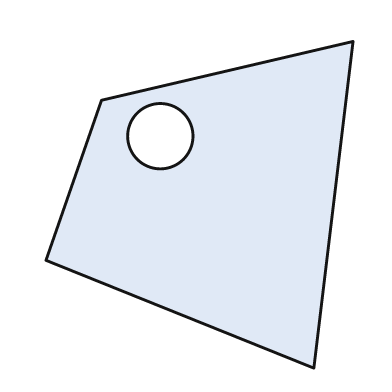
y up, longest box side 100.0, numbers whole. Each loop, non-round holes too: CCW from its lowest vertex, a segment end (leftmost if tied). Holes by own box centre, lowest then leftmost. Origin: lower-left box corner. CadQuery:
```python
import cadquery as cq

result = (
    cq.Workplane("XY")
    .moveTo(82.0, 0.0)
    .lineTo(94.0, 100.0)
    .lineTo(17.0, 82.0)
    .lineTo(0.0, 33.0)
    .close()
    .moveTo(35.0, 71.0)
    .circle(10.0)
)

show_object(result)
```